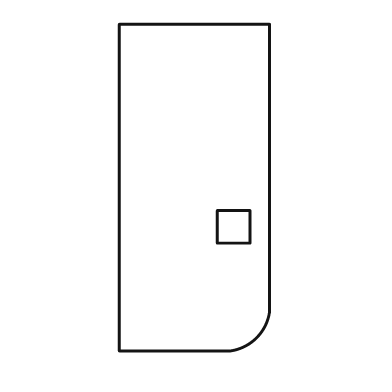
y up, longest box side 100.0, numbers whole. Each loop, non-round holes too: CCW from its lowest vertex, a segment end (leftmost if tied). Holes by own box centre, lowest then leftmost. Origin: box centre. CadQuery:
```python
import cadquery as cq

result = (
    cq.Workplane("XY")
    .moveTo(-23.0, -50.0)
    .lineTo(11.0, -50.0)
    .threePointArc((19.0, -46.0), (23.0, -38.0))
    .lineTo(23.0, 50.0)
    .lineTo(-23.0, 50.0)
    .close()
    .moveTo(7.0, -17.0)
    .lineTo(17.0, -17.0)
    .lineTo(17.0, -7.0)
    .lineTo(7.0, -7.0)
    .close()
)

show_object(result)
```